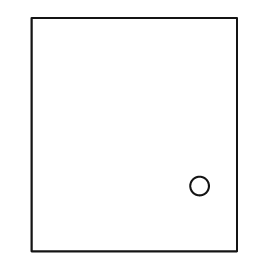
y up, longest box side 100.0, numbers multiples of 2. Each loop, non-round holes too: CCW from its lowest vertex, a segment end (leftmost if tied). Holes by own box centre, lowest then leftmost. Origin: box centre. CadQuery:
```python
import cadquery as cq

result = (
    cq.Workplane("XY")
    .moveTo(-44.0, -50.0)
    .lineTo(44.0, -50.0)
    .lineTo(44.0, 50.0)
    .lineTo(-44.0, 50.0)
    .close()
    .moveTo(28.0, -22.0)
    .circle(4.0)
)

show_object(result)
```